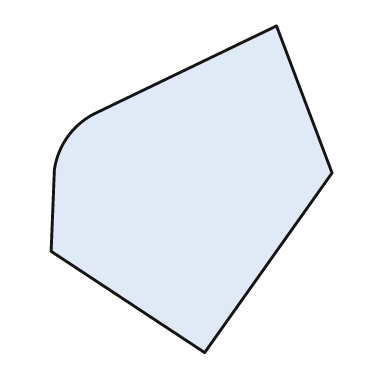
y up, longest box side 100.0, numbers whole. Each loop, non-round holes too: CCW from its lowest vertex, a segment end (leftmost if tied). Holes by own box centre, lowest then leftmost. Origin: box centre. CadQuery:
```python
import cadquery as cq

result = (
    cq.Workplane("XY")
    .moveTo(4.0, -50.0)
    .lineTo(43.0, 5.0)
    .lineTo(26.0, 50.0)
    .lineTo(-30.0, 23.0)
    .threePointArc((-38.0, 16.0), (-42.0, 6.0))
    .lineTo(-43.0, -19.0)
    .close()
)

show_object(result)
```